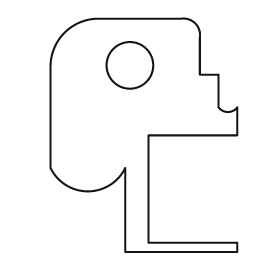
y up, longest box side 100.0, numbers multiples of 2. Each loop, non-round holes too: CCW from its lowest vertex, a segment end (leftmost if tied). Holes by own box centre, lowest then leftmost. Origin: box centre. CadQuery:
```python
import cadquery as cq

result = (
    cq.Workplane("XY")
    .moveTo(-8.0, -50.0)
    .lineTo(40.0, -50.0)
    .lineTo(40.0, -46.0)
    .lineTo(2.0, -46.0)
    .lineTo(2.0, 0.0)
    .lineTo(40.0, 0.0)
    .lineTo(40.0, 12.0)
    .threePointArc((36.0, 10.0), (32.0, 12.0))
    .lineTo(32.0, 26.0)
    .lineTo(24.0, 26.0)
    .lineTo(24.0, 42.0)
    .threePointArc((22.0, 48.0), (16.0, 50.0))
    .lineTo(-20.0, 50.0)
    .threePointArc((-34.0, 44.0), (-40.0, 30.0))
    .lineTo(-40.0, -14.0)
    .threePointArc((-24.0, -24.0), (-8.0, -14.0))
    .close()
    .moveTo(-6.0, 30.0)
    .circle(10.0)
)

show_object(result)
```